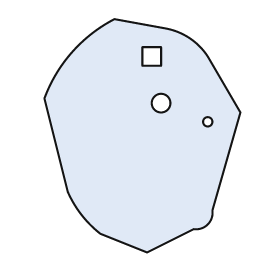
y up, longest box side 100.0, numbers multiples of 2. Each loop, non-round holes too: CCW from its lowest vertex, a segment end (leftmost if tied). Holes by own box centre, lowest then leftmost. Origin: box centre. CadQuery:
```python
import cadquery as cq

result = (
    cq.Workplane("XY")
    .moveTo(2.0, -50.0)
    .lineTo(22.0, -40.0)
    .threePointArc((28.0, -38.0), (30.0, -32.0))
    .lineTo(42.0, 10.0)
    .lineTo(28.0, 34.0)
    .threePointArc((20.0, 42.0), (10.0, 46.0))
    .lineTo(-12.0, 50.0)
    .threePointArc((-30.0, 36.0), (-42.0, 16.0))
    .lineTo(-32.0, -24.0)
    .threePointArc((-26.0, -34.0), (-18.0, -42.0))
    .close()
    .moveTo(28.0, 6.0)
    .circle(2.0)
    .moveTo(8.0, 14.0)
    .circle(4.0)
    .moveTo(0.0, 30.0)
    .lineTo(8.0, 30.0)
    .lineTo(8.0, 38.0)
    .lineTo(0.0, 38.0)
    .close()
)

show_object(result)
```